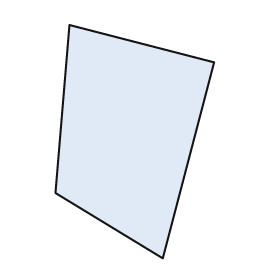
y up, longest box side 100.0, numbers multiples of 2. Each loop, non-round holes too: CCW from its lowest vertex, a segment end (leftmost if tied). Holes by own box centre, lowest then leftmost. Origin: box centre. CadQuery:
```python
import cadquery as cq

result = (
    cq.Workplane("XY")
    .moveTo(12.0, -50.0)
    .lineTo(34.0, 34.0)
    .lineTo(-28.0, 50.0)
    .lineTo(-34.0, -22.0)
    .close()
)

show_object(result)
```